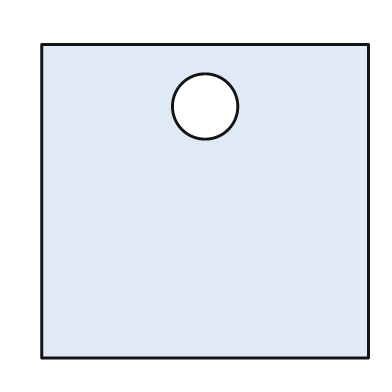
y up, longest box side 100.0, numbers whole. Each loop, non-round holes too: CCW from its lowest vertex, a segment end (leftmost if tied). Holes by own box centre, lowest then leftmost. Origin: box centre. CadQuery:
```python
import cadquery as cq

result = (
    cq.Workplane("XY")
    .moveTo(-50.0, -48.0)
    .lineTo(50.0, -48.0)
    .lineTo(50.0, 48.0)
    .lineTo(-50.0, 48.0)
    .close()
    .moveTo(0.0, 29.0)
    .circle(10.0)
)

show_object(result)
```